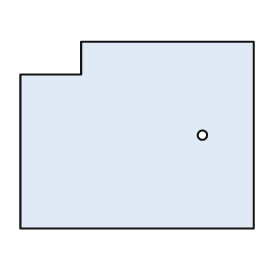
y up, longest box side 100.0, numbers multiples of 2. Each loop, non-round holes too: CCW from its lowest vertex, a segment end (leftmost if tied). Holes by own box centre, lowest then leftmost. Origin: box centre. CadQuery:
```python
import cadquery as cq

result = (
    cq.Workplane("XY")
    .moveTo(-50.0, -40.0)
    .lineTo(50.0, -40.0)
    .lineTo(50.0, 40.0)
    .lineTo(-24.0, 40.0)
    .lineTo(-24.0, 26.0)
    .lineTo(-50.0, 26.0)
    .close()
    .moveTo(28.0, 0.0)
    .circle(2.0)
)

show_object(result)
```